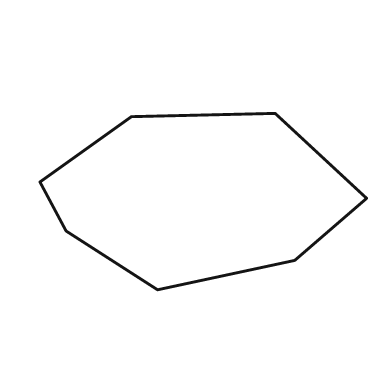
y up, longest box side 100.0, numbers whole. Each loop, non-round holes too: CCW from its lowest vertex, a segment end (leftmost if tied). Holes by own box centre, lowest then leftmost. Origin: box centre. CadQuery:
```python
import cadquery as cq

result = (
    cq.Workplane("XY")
    .moveTo(-14.0, -27.0)
    .lineTo(28.0, -18.0)
    .lineTo(50.0, 1.0)
    .lineTo(22.0, 27.0)
    .lineTo(-22.0, 26.0)
    .lineTo(-50.0, 6.0)
    .lineTo(-42.0, -9.0)
    .close()
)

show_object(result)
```